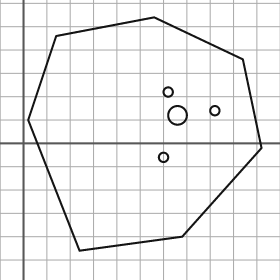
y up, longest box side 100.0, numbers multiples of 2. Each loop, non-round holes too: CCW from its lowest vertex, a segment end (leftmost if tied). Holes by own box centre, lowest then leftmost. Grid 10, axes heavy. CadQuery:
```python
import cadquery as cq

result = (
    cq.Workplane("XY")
    .moveTo(24.0, -46.0)
    .lineTo(68.0, -40.0)
    .lineTo(102.0, -2.0)
    .lineTo(94.0, 36.0)
    .lineTo(56.0, 54.0)
    .lineTo(14.0, 46.0)
    .lineTo(2.0, 10.0)
    .close()
    .moveTo(60.0, -6.0)
    .circle(2.0)
    .moveTo(66.0, 12.0)
    .circle(4.0)
    .moveTo(82.0, 14.0)
    .circle(2.0)
    .moveTo(62.0, 22.0)
    .circle(2.0)
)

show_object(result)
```